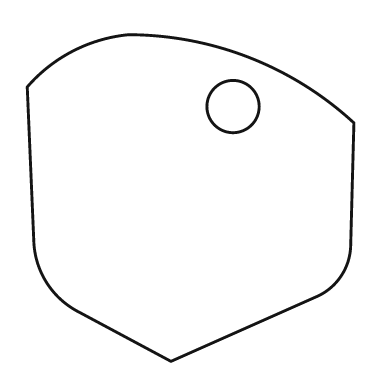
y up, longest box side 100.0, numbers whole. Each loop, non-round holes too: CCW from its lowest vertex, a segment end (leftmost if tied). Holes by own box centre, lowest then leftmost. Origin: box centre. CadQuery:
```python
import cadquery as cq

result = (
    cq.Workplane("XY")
    .moveTo(-6.0, -50.0)
    .lineTo(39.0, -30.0)
    .threePointArc((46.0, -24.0), (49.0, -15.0))
    .lineTo(50.0, 23.0)
    .threePointArc((18.0, 43.0), (-19.0, 50.0))
    .threePointArc((-36.0, 45.0), (-50.0, 34.0))
    .lineTo(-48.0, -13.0)
    .threePointArc((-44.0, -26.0), (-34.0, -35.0))
    .close()
    .moveTo(13.0, 28.0)
    .circle(8.0)
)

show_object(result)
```